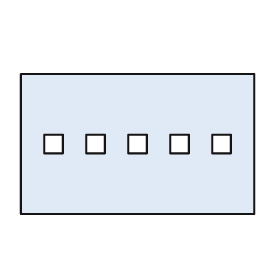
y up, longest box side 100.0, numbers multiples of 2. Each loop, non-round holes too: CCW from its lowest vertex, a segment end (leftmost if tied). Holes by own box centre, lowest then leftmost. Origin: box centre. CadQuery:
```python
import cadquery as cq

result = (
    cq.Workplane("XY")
    .moveTo(-50.0, -30.0)
    .lineTo(50.0, -30.0)
    .lineTo(50.0, 30.0)
    .lineTo(-50.0, 30.0)
    .close()
    .moveTo(-40.0, -4.0)
    .lineTo(-32.0, -4.0)
    .lineTo(-32.0, 4.0)
    .lineTo(-40.0, 4.0)
    .close()
    .moveTo(-22.0, -4.0)
    .lineTo(-14.0, -4.0)
    .lineTo(-14.0, 4.0)
    .lineTo(-22.0, 4.0)
    .close()
    .moveTo(-4.0, -4.0)
    .lineTo(4.0, -4.0)
    .lineTo(4.0, 4.0)
    .lineTo(-4.0, 4.0)
    .close()
    .moveTo(14.0, -4.0)
    .lineTo(22.0, -4.0)
    .lineTo(22.0, 4.0)
    .lineTo(14.0, 4.0)
    .close()
    .moveTo(32.0, -4.0)
    .lineTo(40.0, -4.0)
    .lineTo(40.0, 4.0)
    .lineTo(32.0, 4.0)
    .close()
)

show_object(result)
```